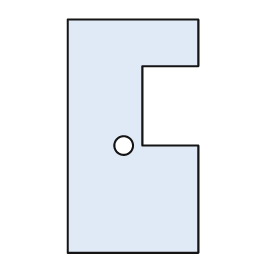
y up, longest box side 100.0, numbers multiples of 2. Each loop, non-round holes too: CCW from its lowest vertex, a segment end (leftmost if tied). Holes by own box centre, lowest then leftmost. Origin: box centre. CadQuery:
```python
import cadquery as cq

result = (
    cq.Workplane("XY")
    .moveTo(-28.0, -50.0)
    .lineTo(28.0, -50.0)
    .lineTo(28.0, -4.0)
    .lineTo(4.0, -4.0)
    .lineTo(4.0, 30.0)
    .lineTo(28.0, 30.0)
    .lineTo(28.0, 50.0)
    .lineTo(-28.0, 50.0)
    .close()
    .moveTo(-4.0, -4.0)
    .circle(4.0)
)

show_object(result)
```